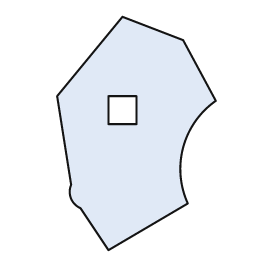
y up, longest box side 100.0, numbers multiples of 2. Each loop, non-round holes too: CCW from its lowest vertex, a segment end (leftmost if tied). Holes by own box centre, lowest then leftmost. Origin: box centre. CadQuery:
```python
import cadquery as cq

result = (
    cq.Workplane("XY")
    .moveTo(-12.0, -50.0)
    .lineTo(22.0, -30.0)
    .threePointArc((20.0, -6.0), (34.0, 14.0))
    .lineTo(20.0, 40.0)
    .lineTo(-6.0, 50.0)
    .lineTo(-34.0, 16.0)
    .lineTo(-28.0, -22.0)
    .threePointArc((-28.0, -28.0), (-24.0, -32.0))
    .close()
    .moveTo(-12.0, 4.0)
    .lineTo(0.0, 4.0)
    .lineTo(0.0, 16.0)
    .lineTo(-12.0, 16.0)
    .close()
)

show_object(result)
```